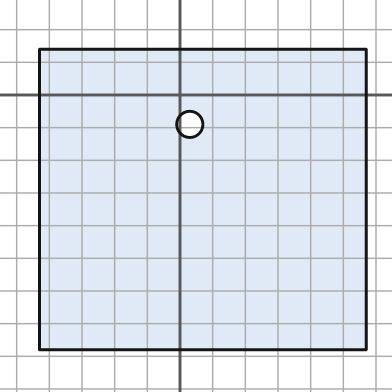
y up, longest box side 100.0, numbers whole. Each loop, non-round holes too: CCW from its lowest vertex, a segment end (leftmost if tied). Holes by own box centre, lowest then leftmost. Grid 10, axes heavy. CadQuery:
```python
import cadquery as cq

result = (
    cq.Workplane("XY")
    .moveTo(-43.0, -78.0)
    .lineTo(57.0, -78.0)
    .lineTo(57.0, 14.0)
    .lineTo(-43.0, 14.0)
    .close()
    .moveTo(3.0, -9.0)
    .circle(4.0)
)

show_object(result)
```